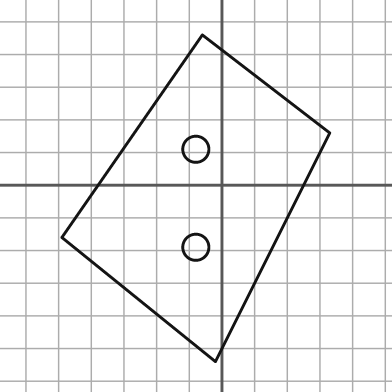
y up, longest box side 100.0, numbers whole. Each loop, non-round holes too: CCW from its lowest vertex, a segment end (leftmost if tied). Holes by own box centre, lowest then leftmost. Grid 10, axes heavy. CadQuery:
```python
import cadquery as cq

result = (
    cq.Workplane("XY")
    .moveTo(-2.0, -54.0)
    .lineTo(33.0, 16.0)
    .lineTo(-6.0, 46.0)
    .lineTo(-49.0, -16.0)
    .close()
    .moveTo(-8.0, -19.0)
    .circle(4.0)
    .moveTo(-8.0, 11.0)
    .circle(4.0)
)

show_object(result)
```